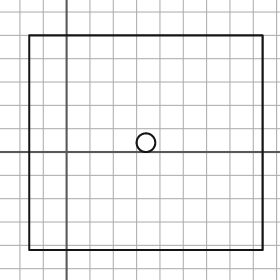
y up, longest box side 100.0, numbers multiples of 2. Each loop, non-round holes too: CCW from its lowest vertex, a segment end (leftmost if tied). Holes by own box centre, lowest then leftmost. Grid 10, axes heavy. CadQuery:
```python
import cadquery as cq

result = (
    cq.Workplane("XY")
    .moveTo(-16.0, -42.0)
    .lineTo(84.0, -42.0)
    .lineTo(84.0, 50.0)
    .lineTo(-16.0, 50.0)
    .close()
    .moveTo(34.0, 4.0)
    .circle(4.0)
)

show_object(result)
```